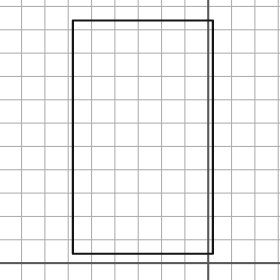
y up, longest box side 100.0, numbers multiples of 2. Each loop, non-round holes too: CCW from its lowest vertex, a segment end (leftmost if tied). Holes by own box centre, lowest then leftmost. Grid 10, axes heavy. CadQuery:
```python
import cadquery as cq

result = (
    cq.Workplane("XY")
    .moveTo(-58.0, 4.0)
    .lineTo(2.0, 4.0)
    .lineTo(2.0, 104.0)
    .lineTo(-58.0, 104.0)
    .close()
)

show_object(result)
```